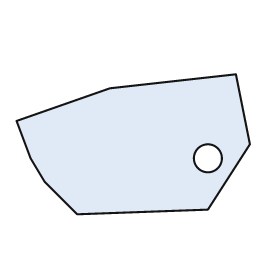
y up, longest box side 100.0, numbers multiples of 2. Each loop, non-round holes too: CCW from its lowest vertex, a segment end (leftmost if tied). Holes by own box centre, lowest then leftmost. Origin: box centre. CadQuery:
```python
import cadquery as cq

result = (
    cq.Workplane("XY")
    .moveTo(-24.0, -30.0)
    .lineTo(32.0, -28.0)
    .lineTo(50.0, 0.0)
    .lineTo(44.0, 30.0)
    .lineTo(-10.0, 24.0)
    .lineTo(-50.0, 10.0)
    .lineTo(-44.0, -6.0)
    .lineTo(-38.0, -16.0)
    .close()
    .moveTo(32.0, -6.0)
    .circle(6.0)
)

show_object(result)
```